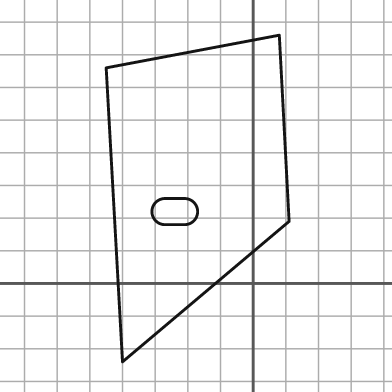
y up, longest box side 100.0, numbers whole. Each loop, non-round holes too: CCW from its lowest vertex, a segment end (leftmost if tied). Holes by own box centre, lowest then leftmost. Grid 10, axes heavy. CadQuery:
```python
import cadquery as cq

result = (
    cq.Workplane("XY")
    .moveTo(-40.0, -24.0)
    .lineTo(11.0, 19.0)
    .lineTo(8.0, 76.0)
    .lineTo(-45.0, 66.0)
    .close()
    .moveTo(-27.0, 18.0)
    .lineTo(-21.0, 18.0)
    .threePointArc((-17.0, 22.0), (-21.0, 26.0))
    .lineTo(-27.0, 26.0)
    .threePointArc((-31.0, 22.0), (-27.0, 18.0))
    .close()
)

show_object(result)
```